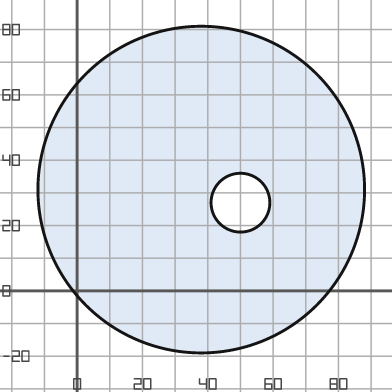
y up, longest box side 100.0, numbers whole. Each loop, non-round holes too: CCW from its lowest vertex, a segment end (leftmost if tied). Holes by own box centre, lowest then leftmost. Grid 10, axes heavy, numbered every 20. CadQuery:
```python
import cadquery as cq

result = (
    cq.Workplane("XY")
    .moveTo(38.0, 31.0)
    .circle(50.0)
    .moveTo(50.0, 27.0)
    .circle(9.0)
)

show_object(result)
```